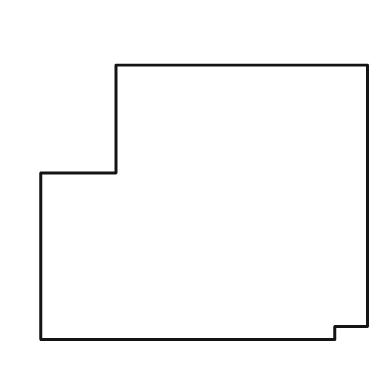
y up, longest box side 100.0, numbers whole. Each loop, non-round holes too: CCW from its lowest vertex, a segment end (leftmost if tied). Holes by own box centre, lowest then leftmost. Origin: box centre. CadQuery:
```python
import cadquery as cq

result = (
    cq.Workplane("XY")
    .moveTo(-50.0, -42.0)
    .lineTo(40.0, -42.0)
    .lineTo(40.0, -38.0)
    .lineTo(50.0, -38.0)
    .lineTo(50.0, 42.0)
    .lineTo(-27.0, 42.0)
    .lineTo(-27.0, 9.0)
    .lineTo(-50.0, 9.0)
    .close()
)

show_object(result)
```